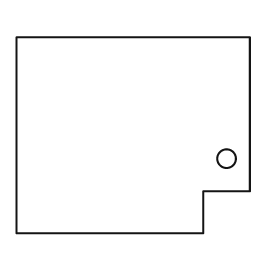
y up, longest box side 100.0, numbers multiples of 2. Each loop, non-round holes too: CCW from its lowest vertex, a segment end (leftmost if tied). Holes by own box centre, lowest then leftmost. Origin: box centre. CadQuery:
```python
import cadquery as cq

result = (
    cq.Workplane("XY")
    .moveTo(-50.0, -42.0)
    .lineTo(30.0, -42.0)
    .lineTo(30.0, -24.0)
    .lineTo(50.0, -24.0)
    .lineTo(50.0, 42.0)
    .lineTo(-50.0, 42.0)
    .close()
    .moveTo(40.0, -10.0)
    .circle(4.0)
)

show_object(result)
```